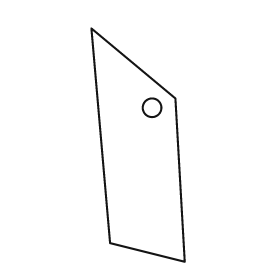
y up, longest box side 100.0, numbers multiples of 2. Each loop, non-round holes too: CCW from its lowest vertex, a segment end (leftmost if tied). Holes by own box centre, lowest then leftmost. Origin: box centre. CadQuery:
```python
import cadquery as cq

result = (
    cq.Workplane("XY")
    .moveTo(20.0, -50.0)
    .lineTo(16.0, 20.0)
    .lineTo(-20.0, 50.0)
    .lineTo(-12.0, -42.0)
    .close()
    .moveTo(6.0, 16.0)
    .circle(4.0)
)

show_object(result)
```